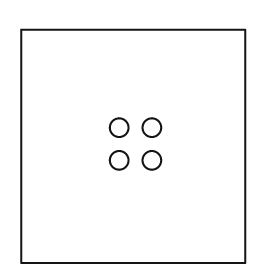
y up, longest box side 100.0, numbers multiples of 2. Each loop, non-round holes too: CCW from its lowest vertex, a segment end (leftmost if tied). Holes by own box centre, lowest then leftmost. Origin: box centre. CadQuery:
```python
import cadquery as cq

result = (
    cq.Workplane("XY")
    .moveTo(-48.0, -50.0)
    .lineTo(48.0, -50.0)
    .lineTo(48.0, 50.0)
    .lineTo(-48.0, 50.0)
    .close()
    .moveTo(-6.0, -6.0)
    .circle(4.0)
    .moveTo(8.0, -6.0)
    .circle(4.0)
    .moveTo(-6.0, 8.0)
    .circle(4.0)
    .moveTo(8.0, 8.0)
    .circle(4.0)
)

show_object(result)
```